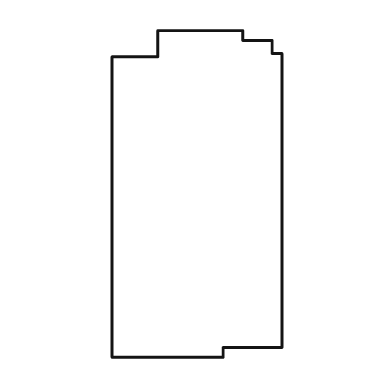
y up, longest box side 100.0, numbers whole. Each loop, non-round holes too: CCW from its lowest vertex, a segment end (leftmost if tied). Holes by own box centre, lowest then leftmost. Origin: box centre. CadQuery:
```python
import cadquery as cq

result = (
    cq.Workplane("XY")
    .moveTo(-26.0, -50.0)
    .lineTo(8.0, -50.0)
    .lineTo(8.0, -47.0)
    .lineTo(26.0, -47.0)
    .lineTo(26.0, 43.0)
    .lineTo(23.0, 43.0)
    .lineTo(23.0, 47.0)
    .lineTo(14.0, 47.0)
    .lineTo(14.0, 50.0)
    .lineTo(-12.0, 50.0)
    .lineTo(-12.0, 42.0)
    .lineTo(-26.0, 42.0)
    .close()
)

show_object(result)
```